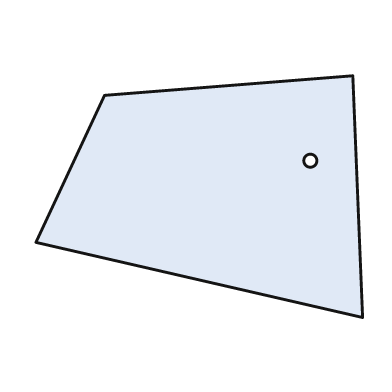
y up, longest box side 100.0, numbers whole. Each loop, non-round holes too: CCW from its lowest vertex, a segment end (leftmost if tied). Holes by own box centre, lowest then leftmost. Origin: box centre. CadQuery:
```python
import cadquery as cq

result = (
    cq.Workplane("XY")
    .moveTo(50.0, -37.0)
    .lineTo(47.0, 37.0)
    .lineTo(-29.0, 31.0)
    .lineTo(-50.0, -14.0)
    .close()
    .moveTo(34.0, 11.0)
    .circle(2.0)
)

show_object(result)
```